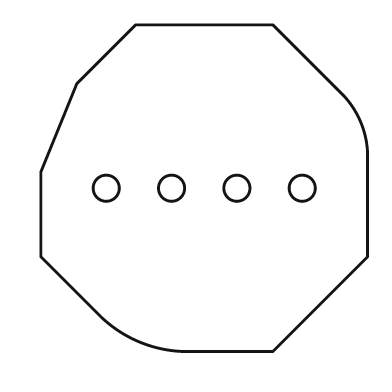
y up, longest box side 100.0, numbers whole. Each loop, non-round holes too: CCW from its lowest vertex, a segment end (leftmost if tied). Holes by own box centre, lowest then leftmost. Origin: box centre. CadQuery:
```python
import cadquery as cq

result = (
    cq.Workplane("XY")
    .moveTo(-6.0, -50.0)
    .lineTo(21.0, -50.0)
    .lineTo(50.0, -21.0)
    .lineTo(50.0, 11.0)
    .threePointArc((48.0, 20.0), (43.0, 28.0))
    .lineTo(21.0, 50.0)
    .lineTo(-21.0, 50.0)
    .lineTo(-39.0, 32.0)
    .lineTo(-50.0, 5.0)
    .lineTo(-50.0, -21.0)
    .lineTo(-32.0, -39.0)
    .threePointArc((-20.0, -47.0), (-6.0, -50.0))
    .close()
    .moveTo(-30.0, 0.0)
    .circle(4.0)
    .moveTo(-10.0, 0.0)
    .circle(4.0)
    .moveTo(10.0, 0.0)
    .circle(4.0)
    .moveTo(30.0, 0.0)
    .circle(4.0)
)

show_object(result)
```